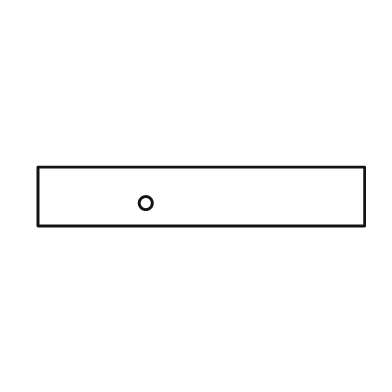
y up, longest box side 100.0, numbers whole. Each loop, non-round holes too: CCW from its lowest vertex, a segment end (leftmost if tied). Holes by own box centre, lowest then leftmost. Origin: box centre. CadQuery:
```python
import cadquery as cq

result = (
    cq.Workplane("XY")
    .moveTo(-50.0, -9.0)
    .lineTo(50.0, -9.0)
    .lineTo(50.0, 9.0)
    .lineTo(-50.0, 9.0)
    .close()
    .moveTo(-17.0, -2.0)
    .circle(2.0)
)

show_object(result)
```